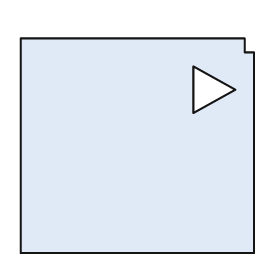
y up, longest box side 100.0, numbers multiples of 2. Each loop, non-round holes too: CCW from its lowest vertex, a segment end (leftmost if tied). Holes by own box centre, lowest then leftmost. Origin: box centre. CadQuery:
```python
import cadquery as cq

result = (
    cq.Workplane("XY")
    .moveTo(-50.0, -46.0)
    .lineTo(50.0, -46.0)
    .lineTo(50.0, 40.0)
    .lineTo(46.0, 40.0)
    .lineTo(46.0, 46.0)
    .lineTo(-50.0, 46.0)
    .close()
    .moveTo(24.0, 14.0)
    .lineTo(42.0, 24.0)
    .lineTo(24.0, 34.0)
    .close()
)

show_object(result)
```